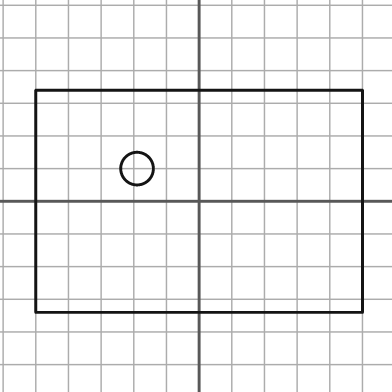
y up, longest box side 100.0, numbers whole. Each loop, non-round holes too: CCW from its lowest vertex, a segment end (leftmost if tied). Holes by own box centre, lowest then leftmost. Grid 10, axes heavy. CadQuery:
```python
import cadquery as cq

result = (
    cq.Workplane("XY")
    .moveTo(-50.0, -34.0)
    .lineTo(50.0, -34.0)
    .lineTo(50.0, 34.0)
    .lineTo(-50.0, 34.0)
    .close()
    .moveTo(-19.0, 10.0)
    .circle(5.0)
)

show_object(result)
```